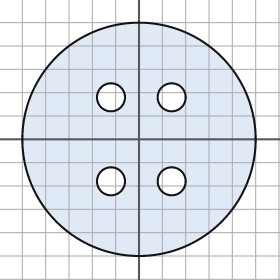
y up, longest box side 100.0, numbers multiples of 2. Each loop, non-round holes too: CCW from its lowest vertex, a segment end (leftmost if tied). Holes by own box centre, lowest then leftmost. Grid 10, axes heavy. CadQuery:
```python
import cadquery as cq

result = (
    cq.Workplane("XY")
    .moveTo(0.0, 0.0)
    .circle(50.0)
    .moveTo(-12.0, -18.0)
    .circle(6.0)
    .moveTo(14.0, -18.0)
    .circle(6.0)
    .moveTo(-12.0, 18.0)
    .circle(6.0)
    .moveTo(14.0, 18.0)
    .circle(6.0)
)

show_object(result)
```